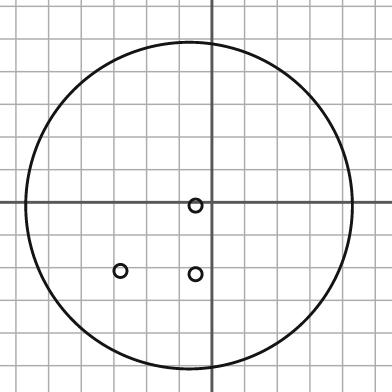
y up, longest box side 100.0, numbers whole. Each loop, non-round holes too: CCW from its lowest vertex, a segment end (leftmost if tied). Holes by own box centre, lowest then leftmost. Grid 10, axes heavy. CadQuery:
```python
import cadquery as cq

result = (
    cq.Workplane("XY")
    .moveTo(-7.0, -1.0)
    .circle(50.0)
    .moveTo(-5.0, -22.0)
    .circle(2.0)
    .moveTo(-28.0, -21.0)
    .circle(2.0)
    .moveTo(-5.0, -1.0)
    .circle(2.0)
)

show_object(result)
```